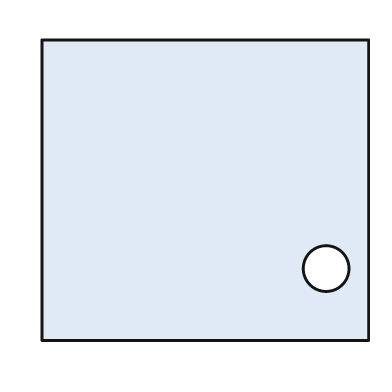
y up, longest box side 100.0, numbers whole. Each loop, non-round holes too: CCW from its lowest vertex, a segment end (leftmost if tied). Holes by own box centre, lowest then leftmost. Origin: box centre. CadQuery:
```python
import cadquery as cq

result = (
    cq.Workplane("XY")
    .moveTo(-50.0, -46.0)
    .lineTo(50.0, -46.0)
    .lineTo(50.0, 46.0)
    .lineTo(-50.0, 46.0)
    .close()
    .moveTo(37.0, -24.0)
    .circle(7.0)
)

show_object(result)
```